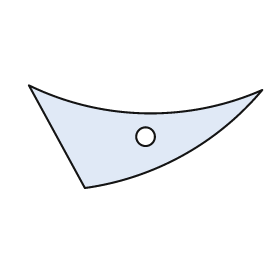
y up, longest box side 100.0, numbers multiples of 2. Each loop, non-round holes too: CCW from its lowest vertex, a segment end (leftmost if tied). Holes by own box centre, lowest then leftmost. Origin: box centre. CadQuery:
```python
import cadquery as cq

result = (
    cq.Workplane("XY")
    .moveTo(-26.0, -22.0)
    .threePointArc((16.0, -8.0), (50.0, 20.0))
    .threePointArc((0.0, 10.0), (-50.0, 22.0))
    .close()
    .moveTo(0.0, 0.0)
    .circle(4.0)
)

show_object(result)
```